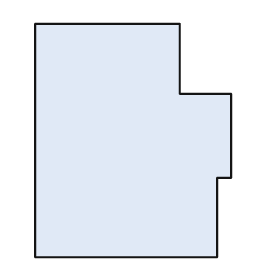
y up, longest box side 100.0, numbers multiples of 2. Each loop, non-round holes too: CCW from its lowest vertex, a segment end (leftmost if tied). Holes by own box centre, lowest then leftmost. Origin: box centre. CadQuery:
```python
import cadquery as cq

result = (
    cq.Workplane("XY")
    .moveTo(-42.0, -50.0)
    .lineTo(36.0, -50.0)
    .lineTo(36.0, -16.0)
    .lineTo(42.0, -16.0)
    .lineTo(42.0, 20.0)
    .lineTo(20.0, 20.0)
    .lineTo(20.0, 50.0)
    .lineTo(-42.0, 50.0)
    .close()
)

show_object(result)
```